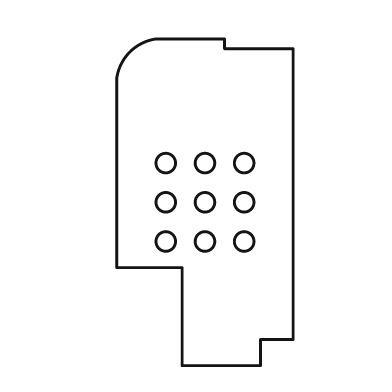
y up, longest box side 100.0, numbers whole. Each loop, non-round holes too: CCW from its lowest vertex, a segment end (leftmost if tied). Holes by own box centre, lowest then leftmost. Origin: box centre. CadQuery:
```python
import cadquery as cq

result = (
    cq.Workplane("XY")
    .moveTo(-7.0, -50.0)
    .lineTo(17.0, -50.0)
    .lineTo(17.0, -42.0)
    .lineTo(27.0, -42.0)
    .lineTo(27.0, 47.0)
    .lineTo(6.0, 47.0)
    .lineTo(6.0, 50.0)
    .lineTo(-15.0, 50.0)
    .threePointArc((-23.0, 46.0), (-27.0, 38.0))
    .lineTo(-27.0, -20.0)
    .lineTo(-7.0, -20.0)
    .close()
    .moveTo(-12.0, -12.0)
    .circle(3.0)
    .moveTo(0.0, -12.0)
    .circle(3.0)
    .moveTo(12.0, -12.0)
    .circle(3.0)
    .moveTo(-12.0, 0.0)
    .circle(3.0)
    .moveTo(0.0, 0.0)
    .circle(3.0)
    .moveTo(12.0, 0.0)
    .circle(3.0)
    .moveTo(-12.0, 12.0)
    .circle(3.0)
    .moveTo(0.0, 12.0)
    .circle(3.0)
    .moveTo(12.0, 12.0)
    .circle(3.0)
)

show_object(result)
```